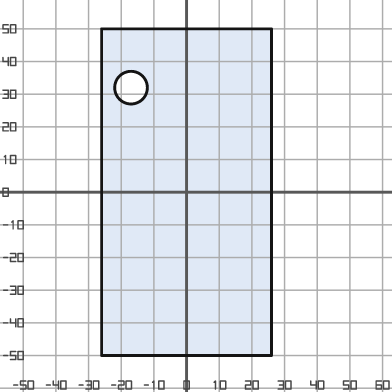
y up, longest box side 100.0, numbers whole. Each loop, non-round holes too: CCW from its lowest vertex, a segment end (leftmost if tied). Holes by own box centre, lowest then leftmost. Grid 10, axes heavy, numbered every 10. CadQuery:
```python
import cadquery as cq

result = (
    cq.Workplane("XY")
    .moveTo(-26.0, -50.0)
    .lineTo(26.0, -50.0)
    .lineTo(26.0, 50.0)
    .lineTo(-26.0, 50.0)
    .close()
    .moveTo(-17.0, 32.0)
    .circle(5.0)
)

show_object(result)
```